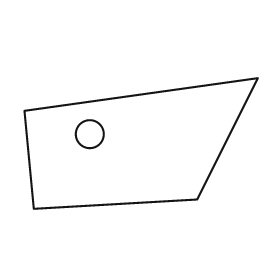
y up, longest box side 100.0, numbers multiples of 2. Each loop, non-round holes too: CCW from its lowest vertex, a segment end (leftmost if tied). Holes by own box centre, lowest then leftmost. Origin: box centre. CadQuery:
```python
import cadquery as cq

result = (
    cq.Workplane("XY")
    .moveTo(-46.0, -28.0)
    .lineTo(24.0, -24.0)
    .lineTo(50.0, 28.0)
    .lineTo(-50.0, 14.0)
    .close()
    .moveTo(-22.0, 4.0)
    .circle(6.0)
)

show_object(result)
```